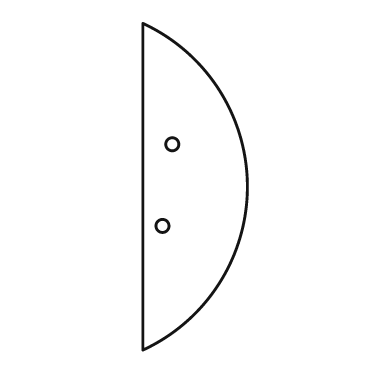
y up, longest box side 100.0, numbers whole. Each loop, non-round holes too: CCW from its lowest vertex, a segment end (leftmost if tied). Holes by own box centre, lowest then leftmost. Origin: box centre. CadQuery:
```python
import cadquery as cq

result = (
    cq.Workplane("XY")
    .moveTo(-16.0, -50.0)
    .threePointArc((16.0, 0.0), (-16.0, 50.0))
    .close()
    .moveTo(-10.0, -12.0)
    .circle(2.0)
    .moveTo(-7.0, 13.0)
    .circle(2.0)
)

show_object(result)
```